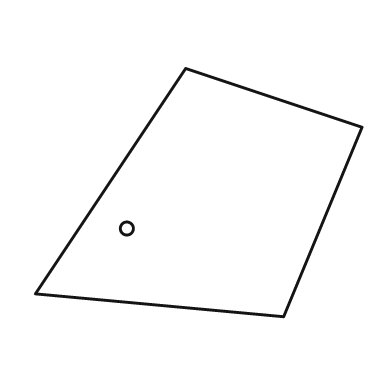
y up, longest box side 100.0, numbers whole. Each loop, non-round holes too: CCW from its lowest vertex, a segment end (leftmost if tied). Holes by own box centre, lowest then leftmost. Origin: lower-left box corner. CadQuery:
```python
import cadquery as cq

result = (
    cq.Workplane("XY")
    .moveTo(76.0, 0.0)
    .lineTo(100.0, 58.0)
    .lineTo(46.0, 76.0)
    .lineTo(0.0, 7.0)
    .close()
    .moveTo(28.0, 27.0)
    .circle(2.0)
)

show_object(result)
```